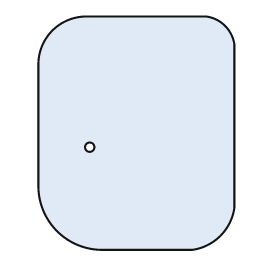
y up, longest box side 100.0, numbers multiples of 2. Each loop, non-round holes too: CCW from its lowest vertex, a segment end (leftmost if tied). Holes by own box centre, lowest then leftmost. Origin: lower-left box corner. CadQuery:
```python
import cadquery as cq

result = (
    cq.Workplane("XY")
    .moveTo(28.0, 0.0)
    .lineTo(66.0, 0.0)
    .threePointArc((78.0, 6.0), (84.0, 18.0))
    .lineTo(84.0, 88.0)
    .threePointArc((80.0, 96.0), (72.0, 100.0))
    .lineTo(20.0, 100.0)
    .threePointArc((6.0, 94.0), (0.0, 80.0))
    .lineTo(0.0, 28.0)
    .threePointArc((8.0, 8.0), (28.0, 0.0))
    .close()
    .moveTo(22.0, 44.0)
    .circle(2.0)
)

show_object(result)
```